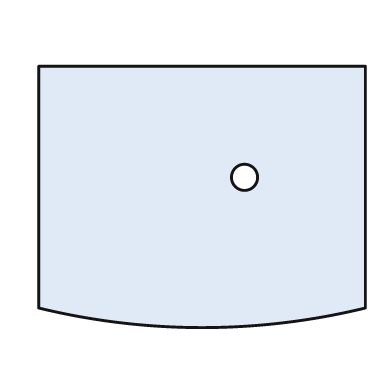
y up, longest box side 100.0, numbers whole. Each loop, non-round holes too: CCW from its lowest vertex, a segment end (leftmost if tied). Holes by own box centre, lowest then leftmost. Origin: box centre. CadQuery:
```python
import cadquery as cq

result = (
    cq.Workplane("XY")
    .moveTo(-50.0, -34.0)
    .threePointArc((0.0, -40.0), (50.0, -34.0))
    .lineTo(50.0, 40.0)
    .lineTo(-50.0, 40.0)
    .close()
    .moveTo(13.0, 6.0)
    .circle(4.0)
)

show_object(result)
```